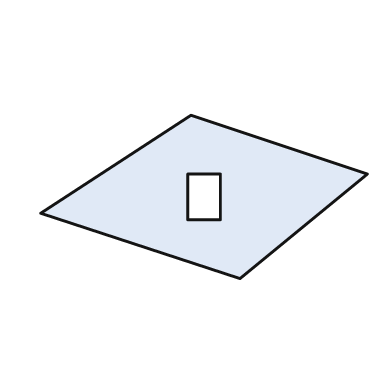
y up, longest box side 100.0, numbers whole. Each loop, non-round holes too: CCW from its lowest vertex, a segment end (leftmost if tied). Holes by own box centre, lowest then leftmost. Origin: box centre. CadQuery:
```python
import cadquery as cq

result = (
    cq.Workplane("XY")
    .moveTo(11.0, -25.0)
    .lineTo(50.0, 7.0)
    .lineTo(-4.0, 25.0)
    .lineTo(-50.0, -5.0)
    .close()
    .moveTo(-5.0, -7.0)
    .lineTo(5.0, -7.0)
    .lineTo(5.0, 7.0)
    .lineTo(-5.0, 7.0)
    .close()
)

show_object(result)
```